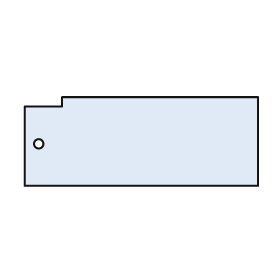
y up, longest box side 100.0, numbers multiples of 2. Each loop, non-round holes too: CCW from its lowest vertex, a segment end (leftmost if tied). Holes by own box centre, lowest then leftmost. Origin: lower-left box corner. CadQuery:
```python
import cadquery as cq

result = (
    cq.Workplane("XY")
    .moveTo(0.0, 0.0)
    .lineTo(100.0, 0.0)
    .lineTo(100.0, 38.0)
    .lineTo(16.0, 38.0)
    .lineTo(16.0, 34.0)
    .lineTo(0.0, 34.0)
    .close()
    .moveTo(6.0, 18.0)
    .circle(2.0)
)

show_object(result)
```